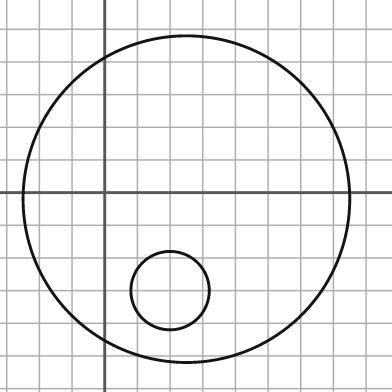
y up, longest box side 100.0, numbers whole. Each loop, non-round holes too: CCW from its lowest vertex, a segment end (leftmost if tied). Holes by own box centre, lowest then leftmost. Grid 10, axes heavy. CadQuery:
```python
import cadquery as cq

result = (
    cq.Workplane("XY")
    .moveTo(25.0, -2.0)
    .circle(50.0)
    .moveTo(20.0, -30.0)
    .circle(12.0)
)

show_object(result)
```